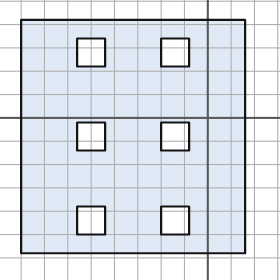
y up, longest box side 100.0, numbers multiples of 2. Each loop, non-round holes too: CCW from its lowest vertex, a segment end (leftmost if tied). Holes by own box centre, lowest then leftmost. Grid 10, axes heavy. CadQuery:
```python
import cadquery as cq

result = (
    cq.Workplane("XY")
    .moveTo(-80.0, -58.0)
    .lineTo(16.0, -58.0)
    .lineTo(16.0, 42.0)
    .lineTo(-80.0, 42.0)
    .close()
    .moveTo(-56.0, -50.0)
    .lineTo(-44.0, -50.0)
    .lineTo(-44.0, -38.0)
    .lineTo(-56.0, -38.0)
    .close()
    .moveTo(-20.0, -50.0)
    .lineTo(-8.0, -50.0)
    .lineTo(-8.0, -38.0)
    .lineTo(-20.0, -38.0)
    .close()
    .moveTo(-56.0, -14.0)
    .lineTo(-44.0, -14.0)
    .lineTo(-44.0, -2.0)
    .lineTo(-56.0, -2.0)
    .close()
    .moveTo(-20.0, -14.0)
    .lineTo(-8.0, -14.0)
    .lineTo(-8.0, -2.0)
    .lineTo(-20.0, -2.0)
    .close()
    .moveTo(-56.0, 22.0)
    .lineTo(-44.0, 22.0)
    .lineTo(-44.0, 34.0)
    .lineTo(-56.0, 34.0)
    .close()
    .moveTo(-20.0, 22.0)
    .lineTo(-8.0, 22.0)
    .lineTo(-8.0, 34.0)
    .lineTo(-20.0, 34.0)
    .close()
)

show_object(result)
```